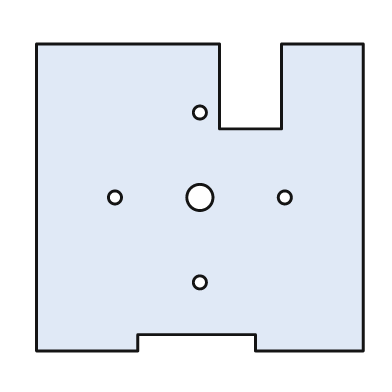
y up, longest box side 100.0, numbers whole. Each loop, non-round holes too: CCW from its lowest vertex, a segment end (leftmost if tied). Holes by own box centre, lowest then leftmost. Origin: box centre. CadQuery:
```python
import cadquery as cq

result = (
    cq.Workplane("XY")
    .moveTo(-50.0, -47.0)
    .lineTo(-19.0, -47.0)
    .lineTo(-19.0, -42.0)
    .lineTo(17.0, -42.0)
    .lineTo(17.0, -47.0)
    .lineTo(50.0, -47.0)
    .lineTo(50.0, 47.0)
    .lineTo(25.0, 47.0)
    .lineTo(25.0, 21.0)
    .lineTo(6.0, 21.0)
    .lineTo(6.0, 47.0)
    .lineTo(-50.0, 47.0)
    .close()
    .moveTo(0.0, -26.0)
    .circle(2.0)
    .moveTo(-26.0, 0.0)
    .circle(2.0)
    .moveTo(0.0, 0.0)
    .circle(4.0)
    .moveTo(26.0, 0.0)
    .circle(2.0)
    .moveTo(0.0, 26.0)
    .circle(2.0)
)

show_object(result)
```